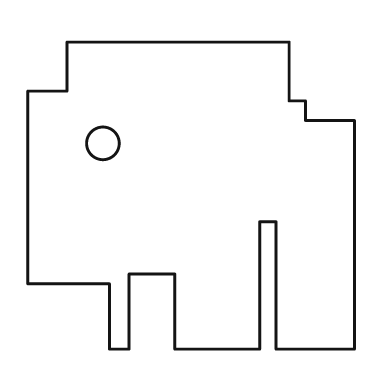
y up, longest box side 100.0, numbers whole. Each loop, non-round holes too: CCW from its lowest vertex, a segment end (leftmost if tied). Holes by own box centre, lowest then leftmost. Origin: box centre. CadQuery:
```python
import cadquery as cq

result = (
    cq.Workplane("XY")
    .moveTo(-25.0, -47.0)
    .lineTo(-19.0, -47.0)
    .lineTo(-19.0, -24.0)
    .lineTo(-5.0, -24.0)
    .lineTo(-5.0, -47.0)
    .lineTo(21.0, -47.0)
    .lineTo(21.0, -8.0)
    .lineTo(26.0, -8.0)
    .lineTo(26.0, -47.0)
    .lineTo(50.0, -47.0)
    .lineTo(50.0, 23.0)
    .lineTo(35.0, 23.0)
    .lineTo(35.0, 29.0)
    .lineTo(30.0, 29.0)
    .lineTo(30.0, 47.0)
    .lineTo(-38.0, 47.0)
    .lineTo(-38.0, 32.0)
    .lineTo(-50.0, 32.0)
    .lineTo(-50.0, -27.0)
    .lineTo(-25.0, -27.0)
    .close()
    .moveTo(-27.0, 16.0)
    .circle(5.0)
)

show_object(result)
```